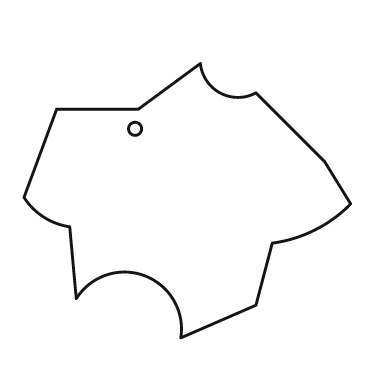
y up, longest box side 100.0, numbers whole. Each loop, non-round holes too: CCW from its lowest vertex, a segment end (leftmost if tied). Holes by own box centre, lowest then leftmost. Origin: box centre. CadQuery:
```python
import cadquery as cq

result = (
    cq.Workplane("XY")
    .moveTo(-2.0, -42.0)
    .lineTo(21.0, -32.0)
    .lineTo(26.0, -13.0)
    .threePointArc((39.0, -9.0), (50.0, -1.0))
    .lineTo(42.0, 12.0)
    .lineTo(21.0, 33.0)
    .threePointArc((10.0, 33.0), (4.0, 42.0))
    .lineTo(-15.0, 28.0)
    .lineTo(-40.0, 28.0)
    .lineTo(-50.0, 1.0)
    .threePointArc((-44.0, -5.0), (-36.0, -8.0))
    .lineTo(-34.0, -30.0)
    .threePointArc((-13.0, -23.0), (-2.0, -42.0))
    .close()
    .moveTo(-16.0, 22.0)
    .circle(2.0)
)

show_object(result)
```